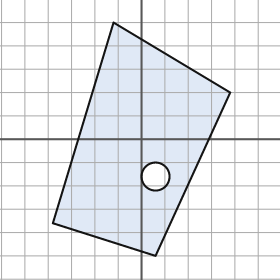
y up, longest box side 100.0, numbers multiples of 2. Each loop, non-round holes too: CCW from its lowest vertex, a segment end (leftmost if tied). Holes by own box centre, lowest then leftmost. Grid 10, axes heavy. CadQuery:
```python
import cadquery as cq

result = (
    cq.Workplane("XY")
    .moveTo(6.0, -50.0)
    .lineTo(38.0, 20.0)
    .lineTo(-12.0, 50.0)
    .lineTo(-38.0, -36.0)
    .close()
    .moveTo(6.0, -16.0)
    .circle(6.0)
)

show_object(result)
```